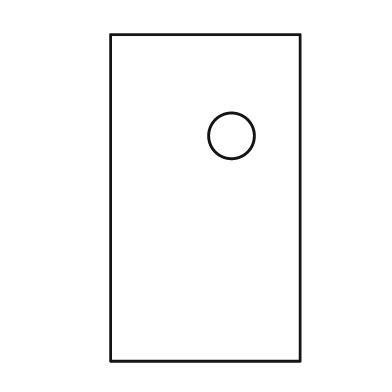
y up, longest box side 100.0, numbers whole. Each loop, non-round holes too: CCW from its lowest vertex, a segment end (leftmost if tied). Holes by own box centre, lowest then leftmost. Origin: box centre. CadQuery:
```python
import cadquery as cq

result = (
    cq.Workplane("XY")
    .moveTo(-29.0, -50.0)
    .lineTo(29.0, -50.0)
    .lineTo(29.0, 50.0)
    .lineTo(-29.0, 50.0)
    .close()
    .moveTo(8.0, 19.0)
    .circle(7.0)
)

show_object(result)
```